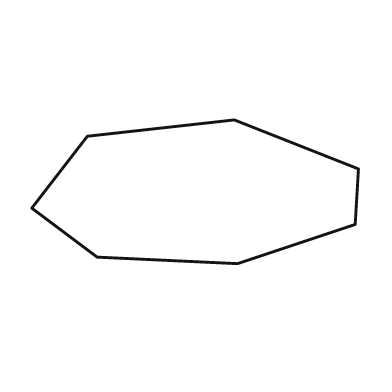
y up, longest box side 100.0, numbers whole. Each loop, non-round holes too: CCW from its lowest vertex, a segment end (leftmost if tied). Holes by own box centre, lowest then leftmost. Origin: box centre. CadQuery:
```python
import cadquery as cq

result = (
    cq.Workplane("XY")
    .moveTo(13.0, -22.0)
    .lineTo(49.0, -10.0)
    .lineTo(50.0, 7.0)
    .lineTo(12.0, 22.0)
    .lineTo(-33.0, 17.0)
    .lineTo(-50.0, -5.0)
    .lineTo(-30.0, -20.0)
    .close()
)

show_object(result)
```